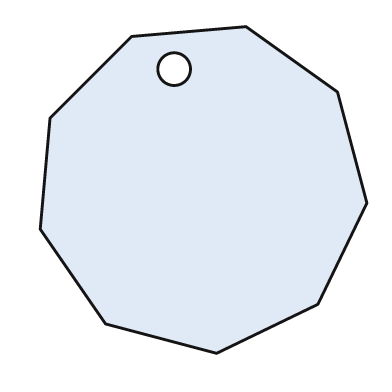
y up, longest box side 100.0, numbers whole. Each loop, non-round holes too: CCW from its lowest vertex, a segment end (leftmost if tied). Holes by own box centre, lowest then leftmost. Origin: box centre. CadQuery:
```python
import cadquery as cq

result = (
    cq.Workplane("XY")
    .moveTo(4.0, -50.0)
    .lineTo(35.0, -35.0)
    .lineTo(50.0, -4.0)
    .lineTo(41.0, 30.0)
    .lineTo(13.0, 50.0)
    .lineTo(-22.0, 47.0)
    .lineTo(-47.0, 22.0)
    .lineTo(-50.0, -12.0)
    .lineTo(-30.0, -41.0)
    .close()
    .moveTo(-9.0, 37.0)
    .circle(5.0)
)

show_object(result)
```